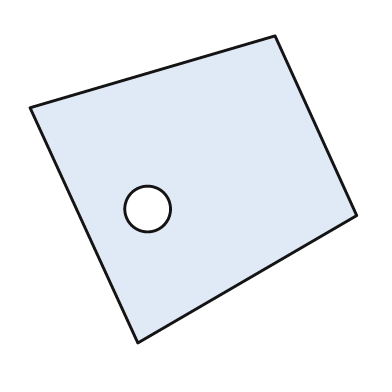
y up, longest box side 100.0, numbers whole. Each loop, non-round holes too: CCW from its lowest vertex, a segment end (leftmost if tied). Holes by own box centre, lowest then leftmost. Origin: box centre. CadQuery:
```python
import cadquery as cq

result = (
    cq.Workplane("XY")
    .moveTo(-17.0, -47.0)
    .lineTo(50.0, -8.0)
    .lineTo(25.0, 47.0)
    .lineTo(-50.0, 25.0)
    .close()
    .moveTo(-14.0, -6.0)
    .circle(7.0)
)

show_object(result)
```